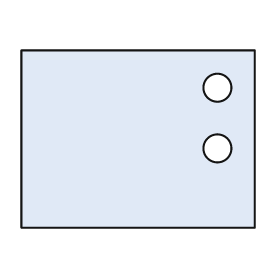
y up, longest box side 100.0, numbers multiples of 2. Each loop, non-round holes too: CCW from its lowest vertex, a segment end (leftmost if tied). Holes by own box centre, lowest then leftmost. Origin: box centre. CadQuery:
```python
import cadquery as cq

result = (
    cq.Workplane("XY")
    .moveTo(-50.0, -38.0)
    .lineTo(50.0, -38.0)
    .lineTo(50.0, 38.0)
    .lineTo(-50.0, 38.0)
    .close()
    .moveTo(34.0, -4.0)
    .circle(6.0)
    .moveTo(34.0, 22.0)
    .circle(6.0)
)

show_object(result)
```